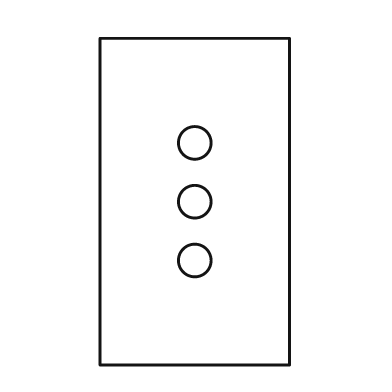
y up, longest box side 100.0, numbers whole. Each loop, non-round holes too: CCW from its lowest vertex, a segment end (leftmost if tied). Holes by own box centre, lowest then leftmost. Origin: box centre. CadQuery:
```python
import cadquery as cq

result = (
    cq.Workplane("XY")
    .moveTo(-29.0, -50.0)
    .lineTo(29.0, -50.0)
    .lineTo(29.0, 50.0)
    .lineTo(-29.0, 50.0)
    .close()
    .moveTo(0.0, -18.0)
    .circle(5.0)
    .moveTo(0.0, 0.0)
    .circle(5.0)
    .moveTo(0.0, 18.0)
    .circle(5.0)
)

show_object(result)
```